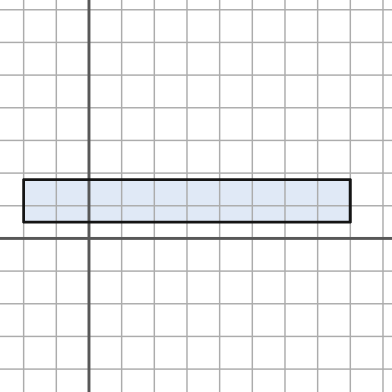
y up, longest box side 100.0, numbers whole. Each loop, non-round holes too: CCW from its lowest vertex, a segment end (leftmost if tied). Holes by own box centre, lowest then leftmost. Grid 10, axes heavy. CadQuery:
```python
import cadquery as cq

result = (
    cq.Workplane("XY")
    .moveTo(-20.0, 5.0)
    .lineTo(80.0, 5.0)
    .lineTo(80.0, 18.0)
    .lineTo(-20.0, 18.0)
    .close()
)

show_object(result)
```